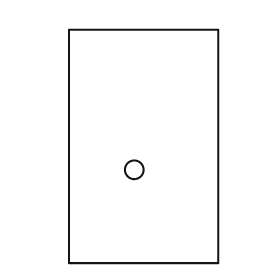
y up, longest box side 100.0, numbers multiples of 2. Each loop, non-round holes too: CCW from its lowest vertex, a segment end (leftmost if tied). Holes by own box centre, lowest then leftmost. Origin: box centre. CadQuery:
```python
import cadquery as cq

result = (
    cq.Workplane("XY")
    .moveTo(-32.0, -50.0)
    .lineTo(32.0, -50.0)
    .lineTo(32.0, 50.0)
    .lineTo(-32.0, 50.0)
    .close()
    .moveTo(-4.0, -10.0)
    .circle(4.0)
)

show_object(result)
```